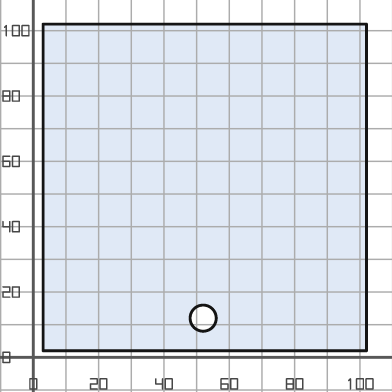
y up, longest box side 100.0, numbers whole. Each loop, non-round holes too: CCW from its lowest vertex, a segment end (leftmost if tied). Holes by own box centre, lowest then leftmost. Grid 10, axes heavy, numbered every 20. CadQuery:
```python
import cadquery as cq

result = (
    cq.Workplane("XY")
    .moveTo(3.0, 2.0)
    .lineTo(102.0, 2.0)
    .lineTo(102.0, 102.0)
    .lineTo(3.0, 102.0)
    .close()
    .moveTo(52.0, 12.0)
    .circle(4.0)
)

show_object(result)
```